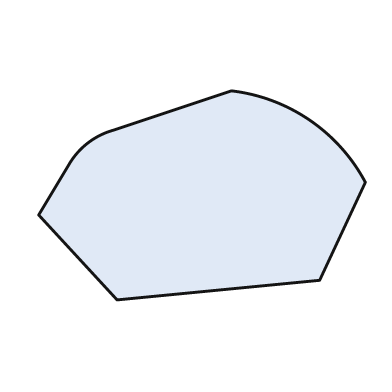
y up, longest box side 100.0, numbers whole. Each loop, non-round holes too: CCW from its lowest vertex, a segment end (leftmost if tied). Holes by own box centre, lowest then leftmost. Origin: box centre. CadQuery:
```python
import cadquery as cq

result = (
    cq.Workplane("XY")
    .moveTo(-26.0, -32.0)
    .lineTo(36.0, -26.0)
    .lineTo(50.0, 4.0)
    .threePointArc((33.0, 23.0), (9.0, 32.0))
    .lineTo(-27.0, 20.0)
    .threePointArc((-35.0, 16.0), (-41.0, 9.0))
    .lineTo(-50.0, -6.0)
    .close()
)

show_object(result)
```